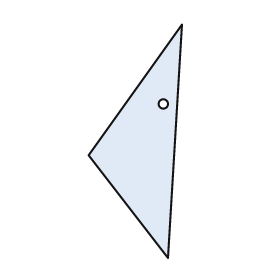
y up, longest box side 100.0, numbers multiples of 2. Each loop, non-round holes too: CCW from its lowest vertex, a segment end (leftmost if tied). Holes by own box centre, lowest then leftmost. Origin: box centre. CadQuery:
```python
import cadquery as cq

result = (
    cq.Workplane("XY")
    .moveTo(14.0, -50.0)
    .lineTo(20.0, 50.0)
    .lineTo(-20.0, -6.0)
    .close()
    .moveTo(12.0, 16.0)
    .circle(2.0)
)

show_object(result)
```